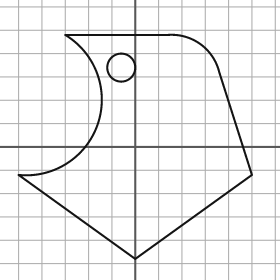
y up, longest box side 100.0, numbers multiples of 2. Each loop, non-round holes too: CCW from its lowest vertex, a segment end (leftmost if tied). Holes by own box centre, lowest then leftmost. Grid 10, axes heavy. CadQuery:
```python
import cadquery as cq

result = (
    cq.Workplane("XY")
    .moveTo(0.0, -48.0)
    .lineTo(50.0, -12.0)
    .lineTo(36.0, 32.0)
    .threePointArc((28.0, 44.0), (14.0, 48.0))
    .lineTo(-30.0, 48.0)
    .threePointArc((-16.0, 10.0), (-50.0, -12.0))
    .close()
    .moveTo(-6.0, 34.0)
    .circle(6.0)
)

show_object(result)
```